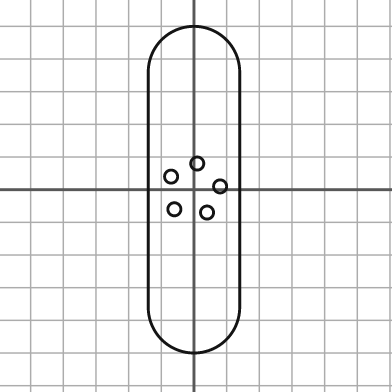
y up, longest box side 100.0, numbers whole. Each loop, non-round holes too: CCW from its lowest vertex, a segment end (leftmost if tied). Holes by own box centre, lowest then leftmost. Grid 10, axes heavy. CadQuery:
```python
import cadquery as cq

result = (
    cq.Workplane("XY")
    .moveTo(-14.0, -36.0)
    .threePointArc((0.0, -50.0), (14.0, -36.0))
    .lineTo(14.0, 36.0)
    .threePointArc((0.0, 50.0), (-14.0, 36.0))
    .close()
    .moveTo(4.0, -7.0)
    .circle(2.0)
    .moveTo(-6.0, -6.0)
    .circle(2.0)
    .moveTo(8.0, 1.0)
    .circle(2.0)
    .moveTo(-7.0, 4.0)
    .circle(2.0)
    .moveTo(1.0, 8.0)
    .circle(2.0)
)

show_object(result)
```